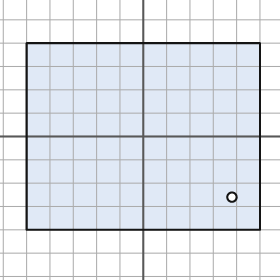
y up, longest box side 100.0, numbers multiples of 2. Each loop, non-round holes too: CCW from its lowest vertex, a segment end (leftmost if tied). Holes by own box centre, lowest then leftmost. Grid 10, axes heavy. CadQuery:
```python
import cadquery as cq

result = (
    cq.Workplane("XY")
    .moveTo(-50.0, -40.0)
    .lineTo(50.0, -40.0)
    .lineTo(50.0, 40.0)
    .lineTo(-50.0, 40.0)
    .close()
    .moveTo(38.0, -26.0)
    .circle(2.0)
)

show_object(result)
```